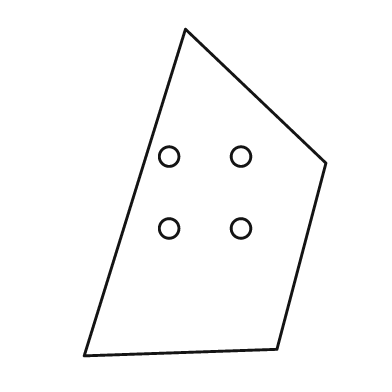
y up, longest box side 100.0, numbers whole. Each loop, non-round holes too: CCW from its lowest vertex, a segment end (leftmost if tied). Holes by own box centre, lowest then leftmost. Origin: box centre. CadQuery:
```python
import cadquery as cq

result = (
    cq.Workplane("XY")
    .moveTo(-37.0, -50.0)
    .lineTo(22.0, -48.0)
    .lineTo(37.0, 9.0)
    .lineTo(-6.0, 50.0)
    .close()
    .moveTo(-11.0, -11.0)
    .circle(3.0)
    .moveTo(11.0, -11.0)
    .circle(3.0)
    .moveTo(-11.0, 11.0)
    .circle(3.0)
    .moveTo(11.0, 11.0)
    .circle(3.0)
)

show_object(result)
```